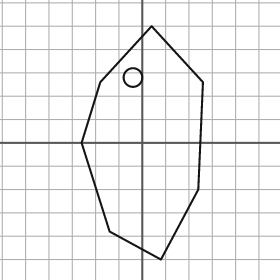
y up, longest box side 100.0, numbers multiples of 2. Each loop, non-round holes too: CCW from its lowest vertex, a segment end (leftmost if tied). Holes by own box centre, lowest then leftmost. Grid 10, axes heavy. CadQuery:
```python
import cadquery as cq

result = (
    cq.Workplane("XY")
    .moveTo(8.0, -50.0)
    .lineTo(24.0, -20.0)
    .lineTo(26.0, 26.0)
    .lineTo(4.0, 50.0)
    .lineTo(-18.0, 26.0)
    .lineTo(-26.0, 0.0)
    .lineTo(-14.0, -38.0)
    .close()
    .moveTo(-4.0, 28.0)
    .circle(4.0)
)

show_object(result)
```